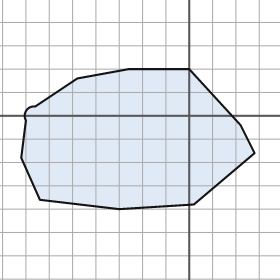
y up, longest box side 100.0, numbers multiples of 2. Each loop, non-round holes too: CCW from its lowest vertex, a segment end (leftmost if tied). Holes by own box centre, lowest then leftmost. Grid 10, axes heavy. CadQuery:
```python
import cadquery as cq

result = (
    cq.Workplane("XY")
    .moveTo(-30.0, -40.0)
    .lineTo(2.0, -38.0)
    .lineTo(28.0, -16.0)
    .lineTo(22.0, -4.0)
    .lineTo(0.0, 20.0)
    .lineTo(-26.0, 20.0)
    .lineTo(-48.0, 16.0)
    .lineTo(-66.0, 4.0)
    .threePointArc((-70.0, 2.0), (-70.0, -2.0))
    .lineTo(-72.0, -18.0)
    .lineTo(-64.0, -36.0)
    .close()
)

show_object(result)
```